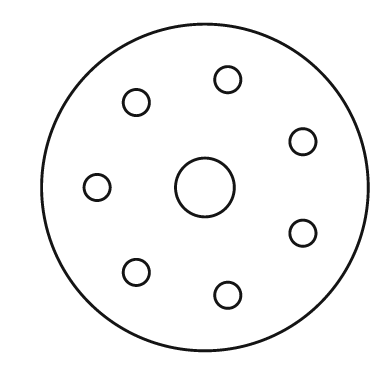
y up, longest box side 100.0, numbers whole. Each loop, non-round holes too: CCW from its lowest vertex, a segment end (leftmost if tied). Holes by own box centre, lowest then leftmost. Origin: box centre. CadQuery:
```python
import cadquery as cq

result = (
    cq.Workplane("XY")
    .moveTo(0.0, 0.0)
    .circle(50.0)
    .moveTo(7.0, -33.0)
    .circle(4.0)
    .moveTo(-21.0, -26.0)
    .circle(4.0)
    .moveTo(30.0, -14.0)
    .circle(4.0)
    .moveTo(-33.0, 0.0)
    .circle(4.0)
    .moveTo(0.0, 0.0)
    .circle(9.0)
    .moveTo(30.0, 14.0)
    .circle(4.0)
    .moveTo(-21.0, 26.0)
    .circle(4.0)
    .moveTo(7.0, 33.0)
    .circle(4.0)
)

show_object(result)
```